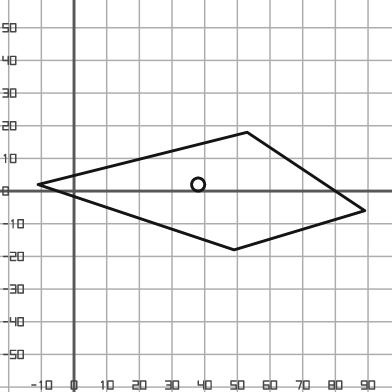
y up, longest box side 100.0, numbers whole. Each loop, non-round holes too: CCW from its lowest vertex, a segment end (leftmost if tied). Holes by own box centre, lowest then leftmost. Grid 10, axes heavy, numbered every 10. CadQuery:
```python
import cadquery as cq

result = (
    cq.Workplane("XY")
    .moveTo(49.0, -18.0)
    .lineTo(89.0, -6.0)
    .lineTo(53.0, 18.0)
    .lineTo(-11.0, 2.0)
    .close()
    .moveTo(38.0, 2.0)
    .circle(2.0)
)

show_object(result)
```